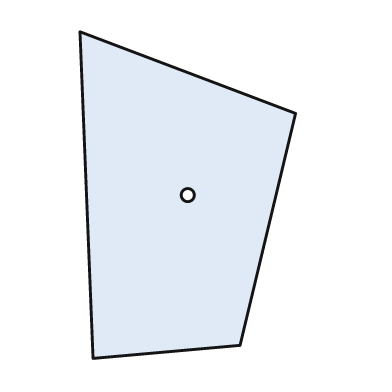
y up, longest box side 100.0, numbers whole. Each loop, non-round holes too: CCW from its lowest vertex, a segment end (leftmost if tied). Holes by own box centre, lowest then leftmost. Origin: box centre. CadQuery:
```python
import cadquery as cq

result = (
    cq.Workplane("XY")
    .moveTo(-29.0, -50.0)
    .lineTo(16.0, -46.0)
    .lineTo(33.0, 25.0)
    .lineTo(-33.0, 50.0)
    .close()
    .moveTo(0.0, 0.0)
    .circle(2.0)
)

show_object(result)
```